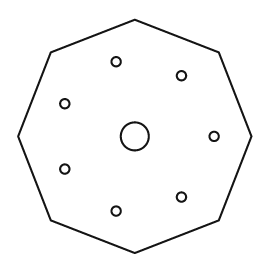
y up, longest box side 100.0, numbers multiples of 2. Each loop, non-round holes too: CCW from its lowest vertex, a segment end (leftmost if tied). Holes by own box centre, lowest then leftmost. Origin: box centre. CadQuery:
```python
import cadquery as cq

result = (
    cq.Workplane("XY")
    .moveTo(0.0, -50.0)
    .lineTo(36.0, -36.0)
    .lineTo(50.0, 0.0)
    .lineTo(36.0, 36.0)
    .lineTo(0.0, 50.0)
    .lineTo(-36.0, 36.0)
    .lineTo(-50.0, 0.0)
    .lineTo(-36.0, -36.0)
    .close()
    .moveTo(-8.0, -32.0)
    .circle(2.0)
    .moveTo(20.0, -26.0)
    .circle(2.0)
    .moveTo(-30.0, -14.0)
    .circle(2.0)
    .moveTo(0.0, 0.0)
    .circle(6.0)
    .moveTo(34.0, 0.0)
    .circle(2.0)
    .moveTo(-30.0, 14.0)
    .circle(2.0)
    .moveTo(20.0, 26.0)
    .circle(2.0)
    .moveTo(-8.0, 32.0)
    .circle(2.0)
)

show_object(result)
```